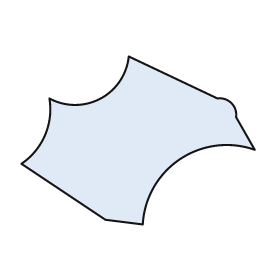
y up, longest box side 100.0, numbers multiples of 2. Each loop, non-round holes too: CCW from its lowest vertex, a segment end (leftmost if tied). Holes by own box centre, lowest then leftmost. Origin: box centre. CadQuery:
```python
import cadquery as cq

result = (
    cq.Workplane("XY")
    .moveTo(2.0, -36.0)
    .threePointArc((18.0, -8.0), (50.0, -4.0))
    .lineTo(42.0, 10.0)
    .threePointArc((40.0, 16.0), (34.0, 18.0))
    .lineTo(-4.0, 36.0)
    .threePointArc((-16.0, 18.0), (-38.0, 18.0))
    .threePointArc((-40.0, 2.0), (-50.0, -10.0))
    .lineTo(-14.0, -34.0)
    .close()
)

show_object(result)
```